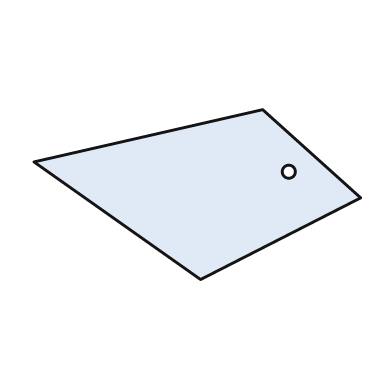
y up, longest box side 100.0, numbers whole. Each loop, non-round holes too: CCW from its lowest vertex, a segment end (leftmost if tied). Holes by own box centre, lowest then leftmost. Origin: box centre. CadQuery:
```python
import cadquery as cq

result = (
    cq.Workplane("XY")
    .moveTo(1.0, -26.0)
    .lineTo(50.0, -1.0)
    .lineTo(20.0, 26.0)
    .lineTo(-50.0, 10.0)
    .close()
    .moveTo(28.0, 7.0)
    .circle(2.0)
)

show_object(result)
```